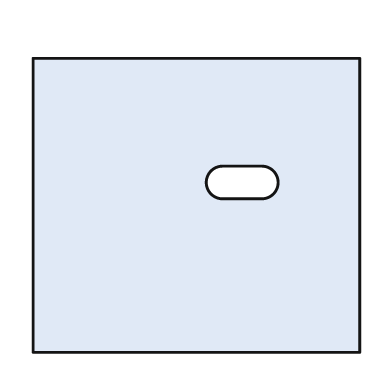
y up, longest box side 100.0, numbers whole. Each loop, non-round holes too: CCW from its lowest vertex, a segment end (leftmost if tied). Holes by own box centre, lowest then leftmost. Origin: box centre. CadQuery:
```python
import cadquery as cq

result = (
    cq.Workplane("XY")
    .moveTo(-50.0, -45.0)
    .lineTo(50.0, -45.0)
    .lineTo(50.0, 45.0)
    .lineTo(-50.0, 45.0)
    .close()
    .moveTo(8.0, 2.0)
    .lineTo(20.0, 2.0)
    .threePointArc((25.0, 7.0), (20.0, 12.0))
    .lineTo(8.0, 12.0)
    .threePointArc((3.0, 7.0), (8.0, 2.0))
    .close()
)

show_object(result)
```